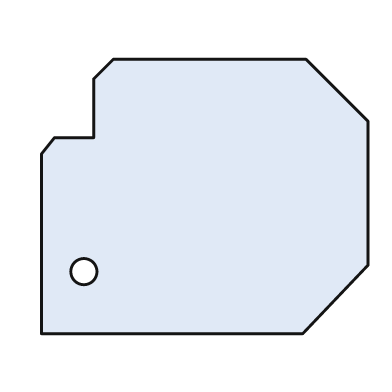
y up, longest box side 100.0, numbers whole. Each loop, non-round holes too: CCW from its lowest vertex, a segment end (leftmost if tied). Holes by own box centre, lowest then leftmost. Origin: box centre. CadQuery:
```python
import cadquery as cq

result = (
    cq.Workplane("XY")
    .moveTo(-50.0, -42.0)
    .lineTo(30.0, -42.0)
    .lineTo(50.0, -21.0)
    .lineTo(50.0, 23.0)
    .lineTo(31.0, 42.0)
    .lineTo(-28.0, 42.0)
    .lineTo(-34.0, 36.0)
    .lineTo(-34.0, 18.0)
    .lineTo(-46.0, 18.0)
    .lineTo(-50.0, 13.0)
    .close()
    .moveTo(-37.0, -23.0)
    .circle(4.0)
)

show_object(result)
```